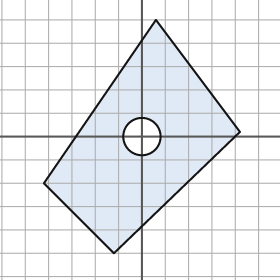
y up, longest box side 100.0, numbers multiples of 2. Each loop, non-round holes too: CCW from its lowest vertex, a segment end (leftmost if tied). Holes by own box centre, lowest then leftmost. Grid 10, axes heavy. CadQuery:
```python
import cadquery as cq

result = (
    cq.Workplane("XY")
    .moveTo(-12.0, -50.0)
    .lineTo(42.0, 2.0)
    .lineTo(6.0, 50.0)
    .lineTo(-42.0, -20.0)
    .close()
    .moveTo(0.0, 0.0)
    .circle(8.0)
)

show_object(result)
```